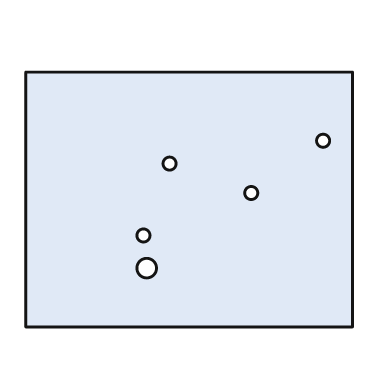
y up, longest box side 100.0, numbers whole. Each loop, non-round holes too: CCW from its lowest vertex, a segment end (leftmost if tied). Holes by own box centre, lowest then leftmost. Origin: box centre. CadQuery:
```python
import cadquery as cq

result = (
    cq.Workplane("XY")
    .moveTo(-50.0, -39.0)
    .lineTo(50.0, -39.0)
    .lineTo(50.0, 39.0)
    .lineTo(-50.0, 39.0)
    .close()
    .moveTo(-13.0, -21.0)
    .circle(3.0)
    .moveTo(-14.0, -11.0)
    .circle(2.0)
    .moveTo(19.0, 2.0)
    .circle(2.0)
    .moveTo(-6.0, 11.0)
    .circle(2.0)
    .moveTo(41.0, 18.0)
    .circle(2.0)
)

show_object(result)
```